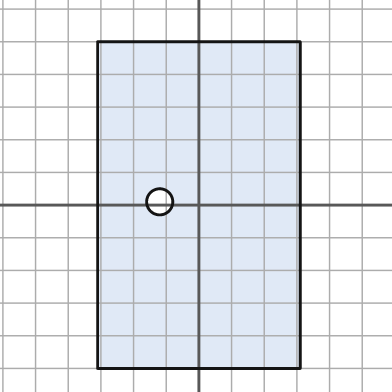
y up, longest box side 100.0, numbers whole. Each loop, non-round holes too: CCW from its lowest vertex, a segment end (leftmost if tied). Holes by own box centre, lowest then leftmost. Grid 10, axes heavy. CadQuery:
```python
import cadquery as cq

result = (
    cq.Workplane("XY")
    .moveTo(-31.0, -50.0)
    .lineTo(31.0, -50.0)
    .lineTo(31.0, 50.0)
    .lineTo(-31.0, 50.0)
    .close()
    .moveTo(-12.0, 1.0)
    .circle(4.0)
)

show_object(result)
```